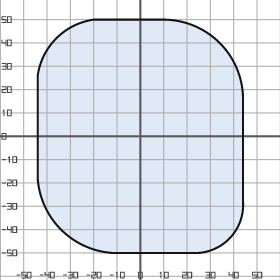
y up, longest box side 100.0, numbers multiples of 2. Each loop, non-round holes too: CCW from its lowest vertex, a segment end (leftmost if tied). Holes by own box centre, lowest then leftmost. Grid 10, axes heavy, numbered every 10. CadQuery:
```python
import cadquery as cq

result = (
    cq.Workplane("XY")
    .moveTo(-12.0, -50.0)
    .lineTo(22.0, -50.0)
    .threePointArc((38.0, -44.0), (44.0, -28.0))
    .lineTo(44.0, 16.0)
    .threePointArc((34.0, 40.0), (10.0, 50.0))
    .lineTo(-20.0, 50.0)
    .threePointArc((-36.0, 42.0), (-44.0, 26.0))
    .lineTo(-44.0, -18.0)
    .threePointArc((-34.0, -40.0), (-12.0, -50.0))
    .close()
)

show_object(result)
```